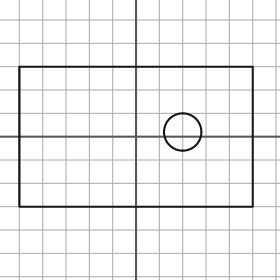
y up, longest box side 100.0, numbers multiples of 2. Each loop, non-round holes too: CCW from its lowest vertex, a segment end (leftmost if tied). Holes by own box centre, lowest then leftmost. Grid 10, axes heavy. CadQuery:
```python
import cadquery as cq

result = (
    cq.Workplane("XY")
    .moveTo(-50.0, -30.0)
    .lineTo(50.0, -30.0)
    .lineTo(50.0, 30.0)
    .lineTo(-50.0, 30.0)
    .close()
    .moveTo(20.0, 2.0)
    .circle(8.0)
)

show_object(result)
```